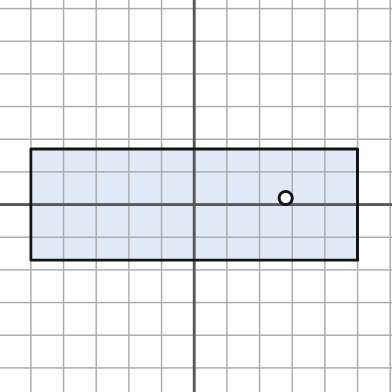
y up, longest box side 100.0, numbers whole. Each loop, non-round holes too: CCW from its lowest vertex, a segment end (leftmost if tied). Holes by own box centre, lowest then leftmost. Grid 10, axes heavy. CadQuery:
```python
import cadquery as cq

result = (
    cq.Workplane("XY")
    .moveTo(-50.0, -17.0)
    .lineTo(50.0, -17.0)
    .lineTo(50.0, 17.0)
    .lineTo(-50.0, 17.0)
    .close()
    .moveTo(28.0, 2.0)
    .circle(2.0)
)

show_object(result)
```